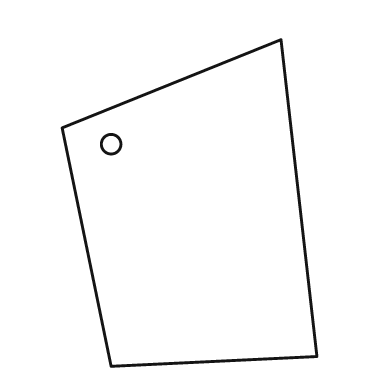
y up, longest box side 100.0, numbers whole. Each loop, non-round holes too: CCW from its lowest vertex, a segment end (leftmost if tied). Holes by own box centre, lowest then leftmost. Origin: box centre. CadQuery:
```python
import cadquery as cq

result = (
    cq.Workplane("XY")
    .moveTo(-24.0, -50.0)
    .lineTo(39.0, -47.0)
    .lineTo(28.0, 50.0)
    .lineTo(-39.0, 23.0)
    .close()
    .moveTo(-24.0, 18.0)
    .circle(3.0)
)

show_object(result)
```